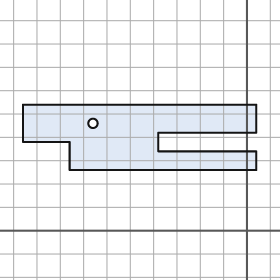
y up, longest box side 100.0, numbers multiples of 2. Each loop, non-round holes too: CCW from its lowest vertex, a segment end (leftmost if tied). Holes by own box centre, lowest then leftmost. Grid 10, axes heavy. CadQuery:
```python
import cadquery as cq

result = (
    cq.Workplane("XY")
    .moveTo(-76.0, 26.0)
    .lineTo(4.0, 26.0)
    .lineTo(4.0, 34.0)
    .lineTo(-38.0, 34.0)
    .lineTo(-38.0, 42.0)
    .lineTo(4.0, 42.0)
    .lineTo(4.0, 54.0)
    .lineTo(-96.0, 54.0)
    .lineTo(-96.0, 38.0)
    .lineTo(-76.0, 38.0)
    .close()
    .moveTo(-66.0, 46.0)
    .circle(2.0)
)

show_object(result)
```